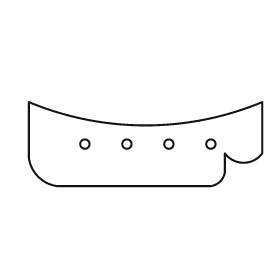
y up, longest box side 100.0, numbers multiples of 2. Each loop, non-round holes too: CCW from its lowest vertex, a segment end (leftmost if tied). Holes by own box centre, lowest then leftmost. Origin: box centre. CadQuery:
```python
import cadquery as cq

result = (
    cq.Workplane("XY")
    .moveTo(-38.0, -18.0)
    .lineTo(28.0, -18.0)
    .threePointArc((32.0, -16.0), (34.0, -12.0))
    .lineTo(34.0, -4.0)
    .threePointArc((42.0, -8.0), (50.0, -4.0))
    .lineTo(50.0, 18.0)
    .threePointArc((0.0, 8.0), (-50.0, 18.0))
    .lineTo(-50.0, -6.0)
    .threePointArc((-46.0, -14.0), (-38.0, -18.0))
    .close()
    .moveTo(-26.0, 0.0)
    .circle(2.0)
    .moveTo(-8.0, 0.0)
    .circle(2.0)
    .moveTo(10.0, 0.0)
    .circle(2.0)
    .moveTo(28.0, 0.0)
    .circle(2.0)
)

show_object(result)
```